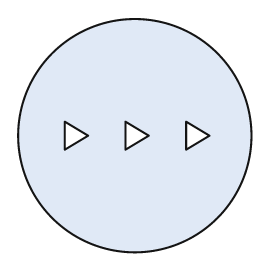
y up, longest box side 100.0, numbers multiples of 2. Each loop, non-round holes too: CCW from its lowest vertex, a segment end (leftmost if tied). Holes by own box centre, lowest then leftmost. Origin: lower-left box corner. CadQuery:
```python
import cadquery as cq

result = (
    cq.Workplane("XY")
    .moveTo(50.0, 50.0)
    .circle(50.0)
    .moveTo(20.0, 44.0)
    .lineTo(30.0, 50.0)
    .lineTo(20.0, 56.0)
    .close()
    .moveTo(46.0, 44.0)
    .lineTo(56.0, 50.0)
    .lineTo(46.0, 56.0)
    .close()
    .moveTo(72.0, 44.0)
    .lineTo(82.0, 50.0)
    .lineTo(72.0, 56.0)
    .close()
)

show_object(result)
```